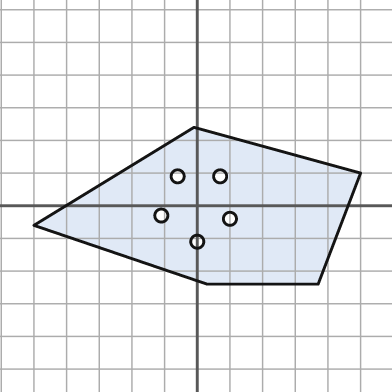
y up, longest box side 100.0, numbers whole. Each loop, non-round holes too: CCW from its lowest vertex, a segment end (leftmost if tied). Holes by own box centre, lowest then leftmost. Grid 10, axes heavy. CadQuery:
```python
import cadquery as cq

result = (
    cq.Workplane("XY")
    .moveTo(3.0, -24.0)
    .lineTo(37.0, -24.0)
    .lineTo(50.0, 10.0)
    .lineTo(-1.0, 24.0)
    .lineTo(-50.0, -6.0)
    .close()
    .moveTo(0.0, -11.0)
    .circle(2.0)
    .moveTo(10.0, -4.0)
    .circle(2.0)
    .moveTo(-11.0, -3.0)
    .circle(2.0)
    .moveTo(-6.0, 9.0)
    .circle(2.0)
    .moveTo(7.0, 9.0)
    .circle(2.0)
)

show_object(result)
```